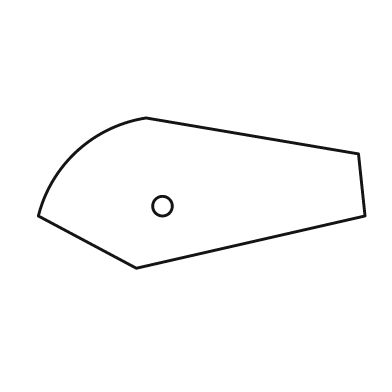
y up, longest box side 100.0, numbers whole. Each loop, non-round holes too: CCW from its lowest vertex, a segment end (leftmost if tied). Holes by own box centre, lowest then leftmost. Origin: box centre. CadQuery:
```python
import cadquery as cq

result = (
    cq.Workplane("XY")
    .moveTo(-20.0, -23.0)
    .lineTo(50.0, -7.0)
    .lineTo(48.0, 12.0)
    .lineTo(-17.0, 23.0)
    .threePointArc((-38.0, 13.0), (-50.0, -7.0))
    .close()
    .moveTo(-12.0, -4.0)
    .circle(3.0)
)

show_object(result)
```